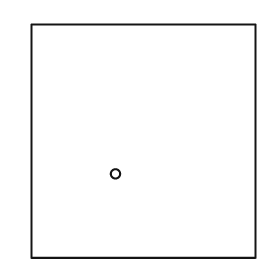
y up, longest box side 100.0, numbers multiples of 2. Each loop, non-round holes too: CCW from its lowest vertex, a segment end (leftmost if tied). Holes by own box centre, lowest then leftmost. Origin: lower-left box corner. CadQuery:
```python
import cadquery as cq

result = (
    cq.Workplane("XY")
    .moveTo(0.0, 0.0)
    .lineTo(96.0, 0.0)
    .lineTo(96.0, 100.0)
    .lineTo(0.0, 100.0)
    .close()
    .moveTo(36.0, 36.0)
    .circle(2.0)
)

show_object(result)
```